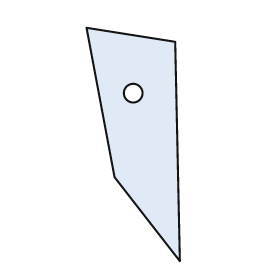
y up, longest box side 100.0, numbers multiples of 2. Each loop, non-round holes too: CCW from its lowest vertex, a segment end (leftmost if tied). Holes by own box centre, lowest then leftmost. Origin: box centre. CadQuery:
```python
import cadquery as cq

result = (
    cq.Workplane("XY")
    .moveTo(20.0, -50.0)
    .lineTo(18.0, 44.0)
    .lineTo(-20.0, 50.0)
    .lineTo(-8.0, -14.0)
    .close()
    .moveTo(0.0, 22.0)
    .circle(4.0)
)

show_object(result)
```